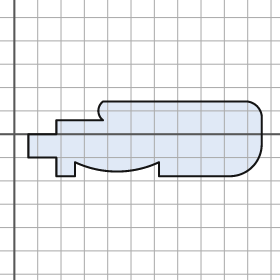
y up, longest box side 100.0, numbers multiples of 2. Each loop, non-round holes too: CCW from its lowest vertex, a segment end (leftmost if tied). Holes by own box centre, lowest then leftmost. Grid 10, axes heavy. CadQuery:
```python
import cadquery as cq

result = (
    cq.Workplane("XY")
    .moveTo(18.0, -18.0)
    .lineTo(26.0, -18.0)
    .lineTo(26.0, -12.0)
    .threePointArc((44.0, -16.0), (62.0, -12.0))
    .lineTo(62.0, -18.0)
    .lineTo(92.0, -18.0)
    .threePointArc((102.0, -14.0), (106.0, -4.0))
    .lineTo(106.0, 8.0)
    .threePointArc((104.0, 12.0), (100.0, 14.0))
    .lineTo(38.0, 14.0)
    .threePointArc((36.0, 10.0), (38.0, 6.0))
    .lineTo(18.0, 6.0)
    .lineTo(18.0, 0.0)
    .lineTo(6.0, 0.0)
    .lineTo(6.0, -10.0)
    .lineTo(18.0, -10.0)
    .close()
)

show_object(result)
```